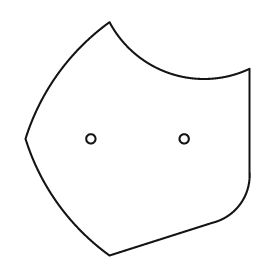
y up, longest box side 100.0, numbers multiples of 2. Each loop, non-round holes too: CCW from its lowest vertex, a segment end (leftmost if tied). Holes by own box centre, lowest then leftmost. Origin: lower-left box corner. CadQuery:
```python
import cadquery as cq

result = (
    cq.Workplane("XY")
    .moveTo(36.0, 0.0)
    .lineTo(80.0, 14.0)
    .threePointArc((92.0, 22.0), (96.0, 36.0))
    .lineTo(96.0, 80.0)
    .threePointArc((62.0, 78.0), (36.0, 100.0))
    .threePointArc((14.0, 78.0), (0.0, 50.0))
    .threePointArc((14.0, 22.0), (36.0, 0.0))
    .close()
    .moveTo(28.0, 50.0)
    .circle(2.0)
    .moveTo(68.0, 50.0)
    .circle(2.0)
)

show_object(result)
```